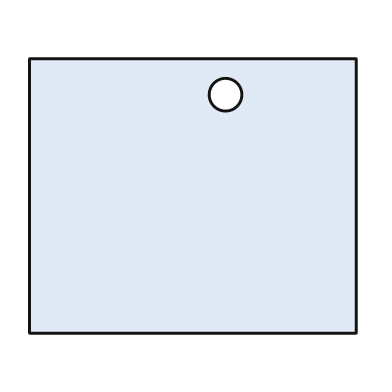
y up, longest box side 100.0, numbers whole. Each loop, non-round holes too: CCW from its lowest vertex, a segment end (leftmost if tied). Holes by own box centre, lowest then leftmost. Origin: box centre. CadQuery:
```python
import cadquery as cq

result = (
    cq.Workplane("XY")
    .moveTo(-50.0, -42.0)
    .lineTo(50.0, -42.0)
    .lineTo(50.0, 42.0)
    .lineTo(-50.0, 42.0)
    .close()
    .moveTo(10.0, 31.0)
    .circle(5.0)
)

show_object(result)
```